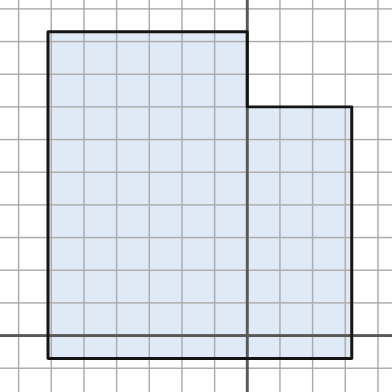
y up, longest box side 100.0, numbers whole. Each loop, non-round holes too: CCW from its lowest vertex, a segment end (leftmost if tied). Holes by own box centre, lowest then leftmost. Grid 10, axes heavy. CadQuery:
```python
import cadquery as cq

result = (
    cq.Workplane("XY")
    .moveTo(-61.0, -7.0)
    .lineTo(32.0, -7.0)
    .lineTo(32.0, 70.0)
    .lineTo(0.0, 70.0)
    .lineTo(0.0, 93.0)
    .lineTo(-61.0, 93.0)
    .close()
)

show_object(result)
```